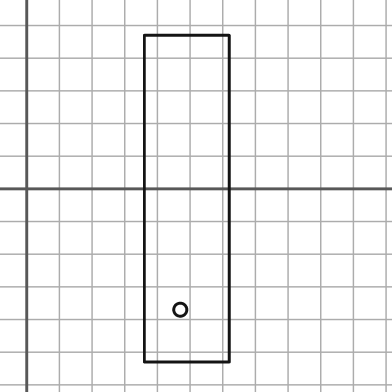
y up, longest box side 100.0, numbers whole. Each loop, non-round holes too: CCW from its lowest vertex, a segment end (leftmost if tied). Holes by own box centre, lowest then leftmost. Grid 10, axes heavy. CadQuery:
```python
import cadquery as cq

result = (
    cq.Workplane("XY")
    .moveTo(36.0, -53.0)
    .lineTo(62.0, -53.0)
    .lineTo(62.0, 47.0)
    .lineTo(36.0, 47.0)
    .close()
    .moveTo(47.0, -37.0)
    .circle(2.0)
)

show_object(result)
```